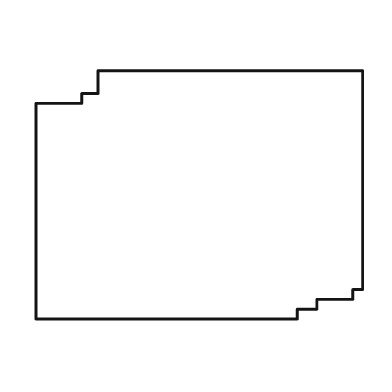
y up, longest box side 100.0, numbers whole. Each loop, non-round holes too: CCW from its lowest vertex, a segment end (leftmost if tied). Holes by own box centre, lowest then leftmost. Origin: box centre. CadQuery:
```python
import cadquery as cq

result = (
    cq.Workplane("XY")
    .moveTo(-50.0, -38.0)
    .lineTo(30.0, -38.0)
    .lineTo(30.0, -35.0)
    .lineTo(36.0, -35.0)
    .lineTo(36.0, -32.0)
    .lineTo(47.0, -32.0)
    .lineTo(47.0, -29.0)
    .lineTo(50.0, -29.0)
    .lineTo(50.0, 38.0)
    .lineTo(-31.0, 38.0)
    .lineTo(-31.0, 31.0)
    .lineTo(-36.0, 31.0)
    .lineTo(-36.0, 28.0)
    .lineTo(-50.0, 28.0)
    .close()
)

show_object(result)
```